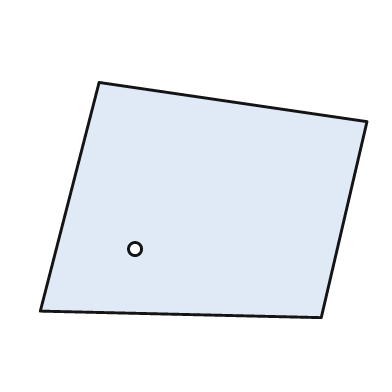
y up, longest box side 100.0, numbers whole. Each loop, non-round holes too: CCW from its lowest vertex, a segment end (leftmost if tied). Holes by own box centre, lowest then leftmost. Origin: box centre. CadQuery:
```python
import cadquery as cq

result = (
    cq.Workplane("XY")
    .moveTo(36.0, -36.0)
    .lineTo(50.0, 24.0)
    .lineTo(-32.0, 36.0)
    .lineTo(-50.0, -34.0)
    .close()
    .moveTo(-21.0, -15.0)
    .circle(2.0)
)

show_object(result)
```